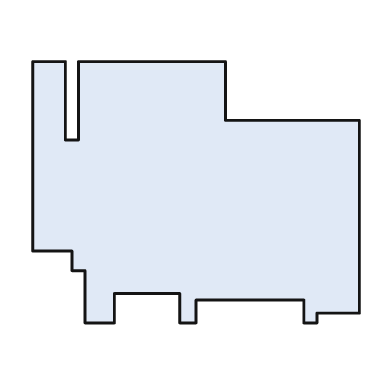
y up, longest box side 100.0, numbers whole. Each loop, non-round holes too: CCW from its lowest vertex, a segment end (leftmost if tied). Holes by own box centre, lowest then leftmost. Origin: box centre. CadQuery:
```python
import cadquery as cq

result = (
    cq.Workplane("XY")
    .moveTo(-34.0, -40.0)
    .lineTo(-25.0, -40.0)
    .lineTo(-25.0, -31.0)
    .lineTo(-5.0, -31.0)
    .lineTo(-5.0, -40.0)
    .lineTo(0.0, -40.0)
    .lineTo(0.0, -33.0)
    .lineTo(33.0, -33.0)
    .lineTo(33.0, -40.0)
    .lineTo(37.0, -40.0)
    .lineTo(37.0, -37.0)
    .lineTo(50.0, -37.0)
    .lineTo(50.0, 22.0)
    .lineTo(9.0, 22.0)
    .lineTo(9.0, 40.0)
    .lineTo(-36.0, 40.0)
    .lineTo(-36.0, 16.0)
    .lineTo(-40.0, 16.0)
    .lineTo(-40.0, 40.0)
    .lineTo(-50.0, 40.0)
    .lineTo(-50.0, -18.0)
    .lineTo(-38.0, -18.0)
    .lineTo(-38.0, -24.0)
    .lineTo(-34.0, -24.0)
    .close()
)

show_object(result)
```